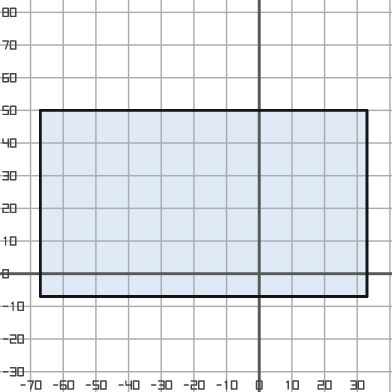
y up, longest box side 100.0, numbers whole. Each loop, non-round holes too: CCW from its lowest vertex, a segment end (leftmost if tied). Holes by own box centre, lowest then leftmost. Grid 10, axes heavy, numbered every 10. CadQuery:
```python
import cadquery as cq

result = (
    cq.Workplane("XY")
    .moveTo(-67.0, -7.0)
    .lineTo(33.0, -7.0)
    .lineTo(33.0, 50.0)
    .lineTo(-67.0, 50.0)
    .close()
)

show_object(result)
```